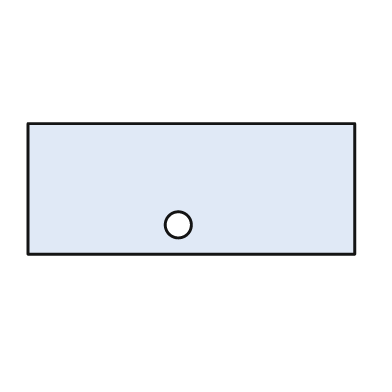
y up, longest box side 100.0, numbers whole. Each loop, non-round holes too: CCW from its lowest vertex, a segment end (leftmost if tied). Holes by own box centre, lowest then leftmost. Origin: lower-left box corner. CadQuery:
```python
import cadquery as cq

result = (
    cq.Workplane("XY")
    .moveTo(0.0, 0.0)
    .lineTo(100.0, 0.0)
    .lineTo(100.0, 40.0)
    .lineTo(0.0, 40.0)
    .close()
    .moveTo(46.0, 9.0)
    .circle(4.0)
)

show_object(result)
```